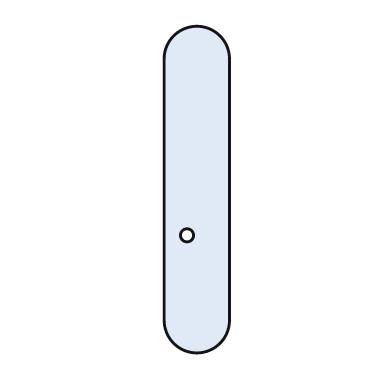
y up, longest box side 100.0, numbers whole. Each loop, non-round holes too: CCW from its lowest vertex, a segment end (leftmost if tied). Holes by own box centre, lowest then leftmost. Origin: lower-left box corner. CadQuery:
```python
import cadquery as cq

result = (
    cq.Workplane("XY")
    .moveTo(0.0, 10.0)
    .threePointArc((10.0, 0.0), (20.0, 10.0))
    .lineTo(20.0, 90.0)
    .threePointArc((10.0, 100.0), (0.0, 90.0))
    .close()
    .moveTo(7.0, 36.0)
    .circle(2.0)
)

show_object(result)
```